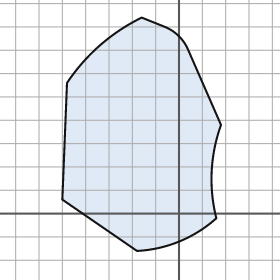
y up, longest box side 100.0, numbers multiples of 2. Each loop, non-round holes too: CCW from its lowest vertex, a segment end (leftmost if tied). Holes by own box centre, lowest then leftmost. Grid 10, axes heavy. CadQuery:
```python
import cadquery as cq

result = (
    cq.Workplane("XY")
    .moveTo(-18.0, -16.0)
    .threePointArc((0.0, -12.0), (16.0, -2.0))
    .threePointArc((14.0, 18.0), (18.0, 38.0))
    .lineTo(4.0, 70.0)
    .threePointArc((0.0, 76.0), (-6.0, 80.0))
    .lineTo(-16.0, 84.0)
    .threePointArc((-34.0, 72.0), (-48.0, 56.0))
    .lineTo(-50.0, 6.0)
    .close()
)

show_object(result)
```